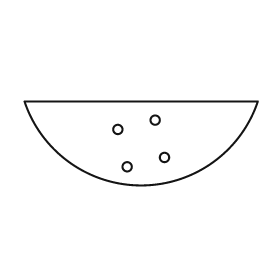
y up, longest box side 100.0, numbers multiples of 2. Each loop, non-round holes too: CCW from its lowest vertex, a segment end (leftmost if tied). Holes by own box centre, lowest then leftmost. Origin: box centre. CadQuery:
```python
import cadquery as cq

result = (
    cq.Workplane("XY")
    .moveTo(-50.0, 18.0)
    .threePointArc((0.0, -18.0), (50.0, 18.0))
    .close()
    .moveTo(-6.0, -10.0)
    .circle(2.0)
    .moveTo(10.0, -6.0)
    .circle(2.0)
    .moveTo(-10.0, 6.0)
    .circle(2.0)
    .moveTo(6.0, 10.0)
    .circle(2.0)
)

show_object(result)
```